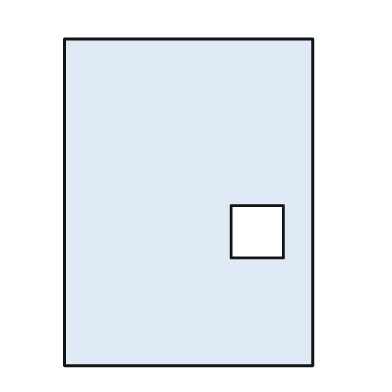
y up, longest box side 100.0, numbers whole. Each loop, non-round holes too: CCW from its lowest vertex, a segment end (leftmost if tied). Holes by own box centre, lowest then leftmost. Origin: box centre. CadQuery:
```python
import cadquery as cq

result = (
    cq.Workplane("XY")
    .moveTo(-38.0, -50.0)
    .lineTo(38.0, -50.0)
    .lineTo(38.0, 50.0)
    .lineTo(-38.0, 50.0)
    .close()
    .moveTo(13.0, -17.0)
    .lineTo(29.0, -17.0)
    .lineTo(29.0, -1.0)
    .lineTo(13.0, -1.0)
    .close()
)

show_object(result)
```